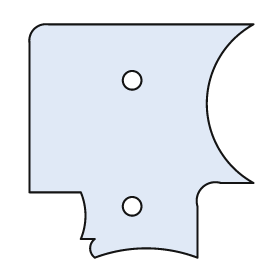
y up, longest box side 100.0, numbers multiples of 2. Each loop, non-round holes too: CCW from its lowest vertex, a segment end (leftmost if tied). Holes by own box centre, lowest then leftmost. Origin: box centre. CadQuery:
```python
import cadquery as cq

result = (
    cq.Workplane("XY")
    .moveTo(-20.0, -50.0)
    .threePointArc((2.0, -46.0), (24.0, -50.0))
    .lineTo(24.0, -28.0)
    .threePointArc((26.0, -20.0), (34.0, -18.0))
    .lineTo(48.0, -18.0)
    .threePointArc((28.0, 16.0), (48.0, 50.0))
    .lineTo(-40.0, 50.0)
    .threePointArc((-46.0, 48.0), (-48.0, 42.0))
    .lineTo(-48.0, -22.0)
    .lineTo(-26.0, -22.0)
    .threePointArc((-24.0, -32.0), (-26.0, -42.0))
    .lineTo(-20.0, -42.0)
    .threePointArc((-22.0, -46.0), (-20.0, -50.0))
    .close()
    .moveTo(-4.0, -28.0)
    .circle(4.0)
    .moveTo(-4.0, 26.0)
    .circle(4.0)
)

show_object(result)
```